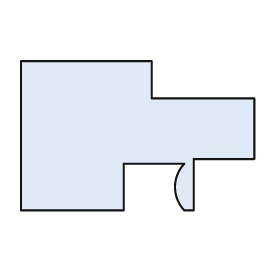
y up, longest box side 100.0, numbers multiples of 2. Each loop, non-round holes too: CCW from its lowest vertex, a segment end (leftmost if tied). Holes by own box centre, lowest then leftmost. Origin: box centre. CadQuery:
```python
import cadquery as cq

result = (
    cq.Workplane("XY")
    .moveTo(-50.0, -32.0)
    .lineTo(-6.0, -32.0)
    .lineTo(-6.0, -12.0)
    .lineTo(20.0, -12.0)
    .threePointArc((16.0, -22.0), (20.0, -32.0))
    .lineTo(24.0, -32.0)
    .lineTo(24.0, -10.0)
    .lineTo(50.0, -10.0)
    .lineTo(50.0, 16.0)
    .lineTo(6.0, 16.0)
    .lineTo(6.0, 32.0)
    .lineTo(-50.0, 32.0)
    .close()
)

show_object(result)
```